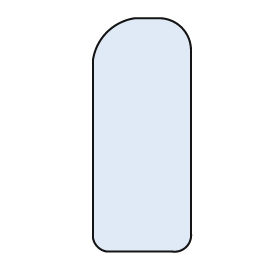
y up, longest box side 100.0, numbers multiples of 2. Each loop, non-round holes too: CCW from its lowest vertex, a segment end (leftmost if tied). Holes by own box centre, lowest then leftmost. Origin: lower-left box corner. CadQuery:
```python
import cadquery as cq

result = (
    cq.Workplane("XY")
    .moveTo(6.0, 0.0)
    .lineTo(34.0, 0.0)
    .threePointArc((40.0, 2.0), (42.0, 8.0))
    .lineTo(42.0, 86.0)
    .threePointArc((38.0, 96.0), (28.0, 100.0))
    .lineTo(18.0, 100.0)
    .threePointArc((6.0, 94.0), (0.0, 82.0))
    .lineTo(0.0, 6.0)
    .threePointArc((2.0, 2.0), (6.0, 0.0))
    .close()
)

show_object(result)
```